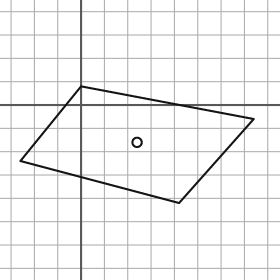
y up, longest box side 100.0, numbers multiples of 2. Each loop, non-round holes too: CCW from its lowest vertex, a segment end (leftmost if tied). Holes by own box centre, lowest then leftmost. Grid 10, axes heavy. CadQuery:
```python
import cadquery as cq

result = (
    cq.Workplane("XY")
    .moveTo(42.0, -42.0)
    .lineTo(74.0, -6.0)
    .lineTo(0.0, 8.0)
    .lineTo(-26.0, -24.0)
    .close()
    .moveTo(24.0, -16.0)
    .circle(2.0)
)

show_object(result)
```